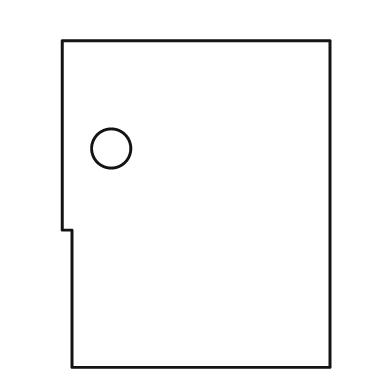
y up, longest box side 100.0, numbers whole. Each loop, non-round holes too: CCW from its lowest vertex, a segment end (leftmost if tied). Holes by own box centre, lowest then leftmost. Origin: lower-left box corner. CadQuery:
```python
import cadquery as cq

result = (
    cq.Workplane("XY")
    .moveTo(3.0, 0.0)
    .lineTo(82.0, 0.0)
    .lineTo(82.0, 100.0)
    .lineTo(0.0, 100.0)
    .lineTo(0.0, 42.0)
    .lineTo(3.0, 42.0)
    .close()
    .moveTo(15.0, 67.0)
    .circle(6.0)
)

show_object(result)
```